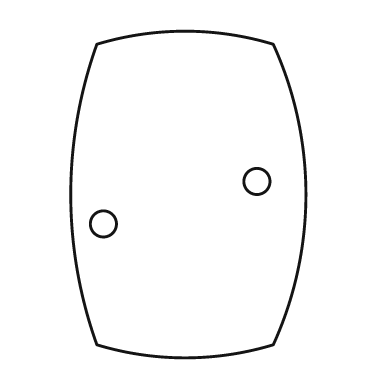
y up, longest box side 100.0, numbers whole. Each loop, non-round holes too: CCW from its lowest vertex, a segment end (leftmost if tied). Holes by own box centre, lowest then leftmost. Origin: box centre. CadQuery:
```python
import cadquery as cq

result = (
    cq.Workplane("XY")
    .moveTo(-28.0, -46.0)
    .threePointArc((-1.0, -50.0), (26.0, -46.0))
    .threePointArc((36.0, 0.0), (26.0, 46.0))
    .threePointArc((-1.0, 50.0), (-28.0, 46.0))
    .threePointArc((-36.0, 0.0), (-28.0, -46.0))
    .close()
    .moveTo(-26.0, -9.0)
    .circle(4.0)
    .moveTo(21.0, 4.0)
    .circle(4.0)
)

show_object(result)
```